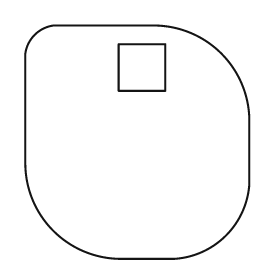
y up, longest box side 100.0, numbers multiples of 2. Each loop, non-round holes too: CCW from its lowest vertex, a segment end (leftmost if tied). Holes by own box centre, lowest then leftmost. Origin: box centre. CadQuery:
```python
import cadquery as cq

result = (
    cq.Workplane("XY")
    .moveTo(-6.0, -50.0)
    .lineTo(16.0, -50.0)
    .threePointArc((38.0, -40.0), (48.0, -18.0))
    .lineTo(48.0, 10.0)
    .threePointArc((36.0, 38.0), (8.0, 50.0))
    .lineTo(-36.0, 50.0)
    .threePointArc((-44.0, 46.0), (-48.0, 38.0))
    .lineTo(-48.0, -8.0)
    .threePointArc((-36.0, -38.0), (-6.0, -50.0))
    .close()
    .moveTo(-8.0, 22.0)
    .lineTo(12.0, 22.0)
    .lineTo(12.0, 42.0)
    .lineTo(-8.0, 42.0)
    .close()
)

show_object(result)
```